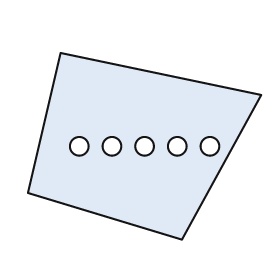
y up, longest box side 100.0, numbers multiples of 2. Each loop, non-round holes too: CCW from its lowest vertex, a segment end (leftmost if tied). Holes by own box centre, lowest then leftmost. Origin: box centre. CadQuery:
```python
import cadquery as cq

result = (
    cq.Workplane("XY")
    .moveTo(16.0, -40.0)
    .lineTo(50.0, 22.0)
    .lineTo(-36.0, 40.0)
    .lineTo(-50.0, -20.0)
    .close()
    .moveTo(-28.0, 0.0)
    .circle(4.0)
    .moveTo(-14.0, 0.0)
    .circle(4.0)
    .moveTo(0.0, 0.0)
    .circle(4.0)
    .moveTo(14.0, 0.0)
    .circle(4.0)
    .moveTo(28.0, 0.0)
    .circle(4.0)
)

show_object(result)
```